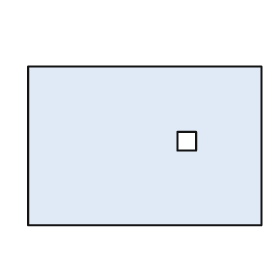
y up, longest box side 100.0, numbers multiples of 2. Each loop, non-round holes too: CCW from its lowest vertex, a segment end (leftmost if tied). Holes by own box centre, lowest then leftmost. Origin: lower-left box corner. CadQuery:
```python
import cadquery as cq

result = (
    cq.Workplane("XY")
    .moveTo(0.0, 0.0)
    .lineTo(100.0, 0.0)
    .lineTo(100.0, 68.0)
    .lineTo(0.0, 68.0)
    .close()
    .moveTo(64.0, 32.0)
    .lineTo(72.0, 32.0)
    .lineTo(72.0, 40.0)
    .lineTo(64.0, 40.0)
    .close()
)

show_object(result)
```